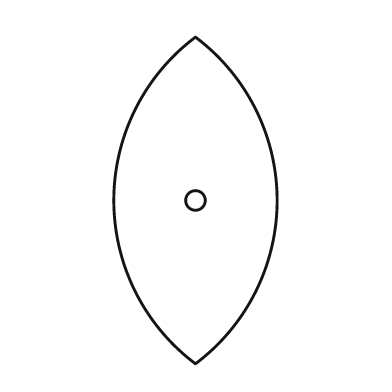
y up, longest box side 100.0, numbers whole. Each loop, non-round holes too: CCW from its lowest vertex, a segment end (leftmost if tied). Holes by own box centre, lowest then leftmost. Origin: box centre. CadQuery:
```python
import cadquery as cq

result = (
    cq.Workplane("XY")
    .moveTo(0.0, -50.0)
    .threePointArc((25.0, 0.0), (0.0, 50.0))
    .threePointArc((-25.0, 0.0), (0.0, -50.0))
    .close()
    .moveTo(0.0, 0.0)
    .circle(3.0)
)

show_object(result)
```